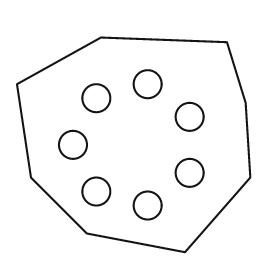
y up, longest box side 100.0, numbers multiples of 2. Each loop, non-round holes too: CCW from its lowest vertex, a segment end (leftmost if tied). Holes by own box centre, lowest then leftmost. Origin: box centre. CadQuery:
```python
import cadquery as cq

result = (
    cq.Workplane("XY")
    .moveTo(22.0, -46.0)
    .lineTo(50.0, -14.0)
    .lineTo(48.0, 18.0)
    .lineTo(40.0, 44.0)
    .lineTo(-14.0, 46.0)
    .lineTo(-50.0, 26.0)
    .lineTo(-44.0, -14.0)
    .lineTo(-20.0, -38.0)
    .close()
    .moveTo(6.0, -26.0)
    .circle(6.0)
    .moveTo(-16.0, -20.0)
    .circle(6.0)
    .moveTo(24.0, -12.0)
    .circle(6.0)
    .moveTo(-26.0, 0.0)
    .circle(6.0)
    .moveTo(24.0, 12.0)
    .circle(6.0)
    .moveTo(-16.0, 20.0)
    .circle(6.0)
    .moveTo(6.0, 26.0)
    .circle(6.0)
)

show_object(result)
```